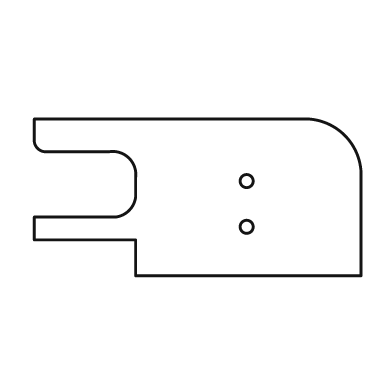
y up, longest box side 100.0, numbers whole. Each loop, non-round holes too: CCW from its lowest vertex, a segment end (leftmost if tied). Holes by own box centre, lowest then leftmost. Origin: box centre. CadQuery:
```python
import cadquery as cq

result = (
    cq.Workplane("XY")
    .moveTo(-19.0, -24.0)
    .lineTo(50.0, -24.0)
    .lineTo(50.0, 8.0)
    .threePointArc((45.0, 19.0), (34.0, 24.0))
    .lineTo(-50.0, 24.0)
    .lineTo(-50.0, 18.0)
    .threePointArc((-49.0, 15.0), (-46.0, 14.0))
    .lineTo(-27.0, 14.0)
    .threePointArc((-21.0, 12.0), (-19.0, 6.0))
    .lineTo(-19.0, 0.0)
    .threePointArc((-21.0, -4.0), (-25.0, -6.0))
    .lineTo(-50.0, -6.0)
    .lineTo(-50.0, -13.0)
    .lineTo(-19.0, -13.0)
    .close()
    .moveTo(15.0, -9.0)
    .circle(2.0)
    .moveTo(15.0, 5.0)
    .circle(2.0)
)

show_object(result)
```